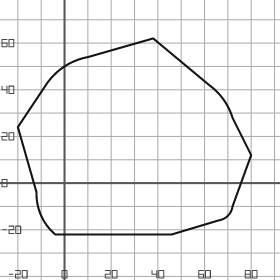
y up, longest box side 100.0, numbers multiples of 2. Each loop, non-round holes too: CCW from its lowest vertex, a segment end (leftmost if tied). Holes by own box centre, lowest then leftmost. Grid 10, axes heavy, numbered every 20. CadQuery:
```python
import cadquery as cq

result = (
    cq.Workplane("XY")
    .moveTo(-4.0, -22.0)
    .lineTo(46.0, -22.0)
    .lineTo(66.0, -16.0)
    .threePointArc((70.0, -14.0), (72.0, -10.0))
    .lineTo(80.0, 12.0)
    .lineTo(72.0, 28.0)
    .threePointArc((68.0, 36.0), (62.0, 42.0))
    .lineTo(38.0, 62.0)
    .lineTo(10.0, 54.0)
    .threePointArc((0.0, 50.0), (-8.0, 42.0))
    .lineTo(-20.0, 24.0)
    .lineTo(-12.0, -4.0)
    .threePointArc((-10.0, -14.0), (-4.0, -22.0))
    .close()
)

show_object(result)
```